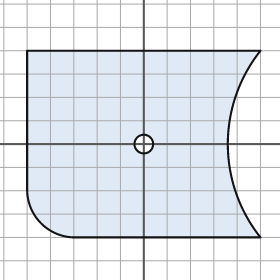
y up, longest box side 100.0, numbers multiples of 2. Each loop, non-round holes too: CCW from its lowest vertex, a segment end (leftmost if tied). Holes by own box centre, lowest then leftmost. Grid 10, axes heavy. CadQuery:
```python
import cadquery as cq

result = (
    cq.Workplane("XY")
    .moveTo(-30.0, -40.0)
    .lineTo(50.0, -40.0)
    .threePointArc((36.0, 0.0), (50.0, 40.0))
    .lineTo(-50.0, 40.0)
    .lineTo(-50.0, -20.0)
    .threePointArc((-44.0, -34.0), (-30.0, -40.0))
    .close()
    .moveTo(0.0, 0.0)
    .circle(4.0)
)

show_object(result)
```